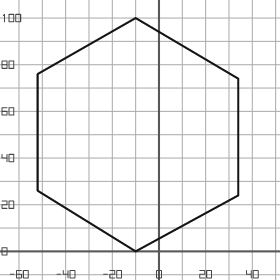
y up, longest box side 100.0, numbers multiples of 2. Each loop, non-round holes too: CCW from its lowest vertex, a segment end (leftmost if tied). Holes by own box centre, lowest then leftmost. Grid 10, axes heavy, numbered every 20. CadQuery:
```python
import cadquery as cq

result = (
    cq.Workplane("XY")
    .moveTo(-10.0, 0.0)
    .lineTo(34.0, 24.0)
    .lineTo(34.0, 74.0)
    .lineTo(-10.0, 100.0)
    .lineTo(-52.0, 76.0)
    .lineTo(-52.0, 26.0)
    .close()
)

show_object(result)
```